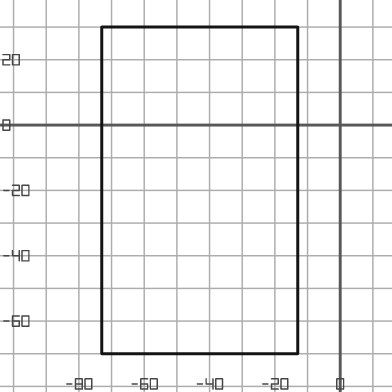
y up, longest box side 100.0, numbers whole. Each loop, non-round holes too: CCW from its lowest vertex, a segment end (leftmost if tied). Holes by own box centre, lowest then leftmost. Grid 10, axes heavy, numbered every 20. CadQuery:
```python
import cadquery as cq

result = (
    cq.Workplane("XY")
    .moveTo(-73.0, -70.0)
    .lineTo(-13.0, -70.0)
    .lineTo(-13.0, 30.0)
    .lineTo(-73.0, 30.0)
    .close()
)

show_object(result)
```